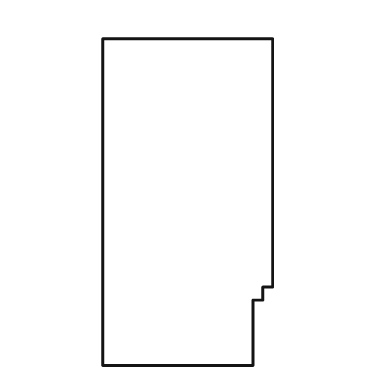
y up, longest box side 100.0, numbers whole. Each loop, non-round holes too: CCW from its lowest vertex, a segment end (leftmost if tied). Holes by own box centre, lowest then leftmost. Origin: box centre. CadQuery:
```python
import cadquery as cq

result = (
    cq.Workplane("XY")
    .moveTo(-26.0, -50.0)
    .lineTo(20.0, -50.0)
    .lineTo(20.0, -30.0)
    .lineTo(23.0, -30.0)
    .lineTo(23.0, -26.0)
    .lineTo(26.0, -26.0)
    .lineTo(26.0, 50.0)
    .lineTo(-26.0, 50.0)
    .close()
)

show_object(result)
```